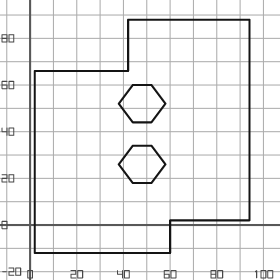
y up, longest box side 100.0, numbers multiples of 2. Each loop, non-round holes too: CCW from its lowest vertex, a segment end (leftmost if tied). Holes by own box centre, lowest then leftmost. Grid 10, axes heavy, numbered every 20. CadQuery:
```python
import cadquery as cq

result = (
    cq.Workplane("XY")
    .moveTo(2.0, -12.0)
    .lineTo(60.0, -12.0)
    .lineTo(60.0, 2.0)
    .lineTo(94.0, 2.0)
    .lineTo(94.0, 88.0)
    .lineTo(42.0, 88.0)
    .lineTo(42.0, 66.0)
    .lineTo(2.0, 66.0)
    .close()
    .moveTo(44.0, 18.0)
    .lineTo(52.0, 18.0)
    .lineTo(58.0, 26.0)
    .lineTo(52.0, 34.0)
    .lineTo(44.0, 34.0)
    .lineTo(38.0, 26.0)
    .close()
    .moveTo(44.0, 44.0)
    .lineTo(52.0, 44.0)
    .lineTo(58.0, 52.0)
    .lineTo(52.0, 60.0)
    .lineTo(44.0, 60.0)
    .lineTo(38.0, 52.0)
    .close()
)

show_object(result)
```